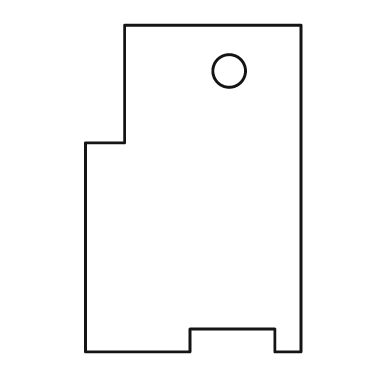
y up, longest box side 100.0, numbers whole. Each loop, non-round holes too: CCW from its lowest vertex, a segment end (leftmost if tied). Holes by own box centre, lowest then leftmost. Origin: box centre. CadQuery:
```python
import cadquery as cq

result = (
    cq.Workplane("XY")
    .moveTo(-33.0, -50.0)
    .lineTo(-1.0, -50.0)
    .lineTo(-1.0, -43.0)
    .lineTo(25.0, -43.0)
    .lineTo(25.0, -50.0)
    .lineTo(33.0, -50.0)
    .lineTo(33.0, 50.0)
    .lineTo(-21.0, 50.0)
    .lineTo(-21.0, 14.0)
    .lineTo(-33.0, 14.0)
    .close()
    .moveTo(11.0, 36.0)
    .circle(5.0)
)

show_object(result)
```